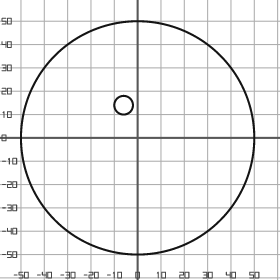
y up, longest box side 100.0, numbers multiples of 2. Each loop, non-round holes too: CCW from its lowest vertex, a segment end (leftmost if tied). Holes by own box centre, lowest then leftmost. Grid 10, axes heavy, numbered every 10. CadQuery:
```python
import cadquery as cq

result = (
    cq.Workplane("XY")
    .moveTo(0.0, 0.0)
    .circle(50.0)
    .moveTo(-6.0, 14.0)
    .circle(4.0)
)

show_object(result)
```